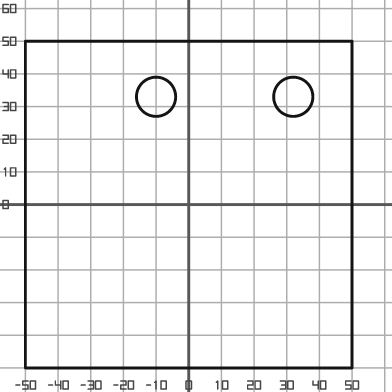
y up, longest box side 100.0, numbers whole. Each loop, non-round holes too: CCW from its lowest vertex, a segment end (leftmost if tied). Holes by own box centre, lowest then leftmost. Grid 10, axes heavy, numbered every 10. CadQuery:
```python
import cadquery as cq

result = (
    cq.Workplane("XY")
    .moveTo(-50.0, -50.0)
    .lineTo(50.0, -50.0)
    .lineTo(50.0, 50.0)
    .lineTo(-50.0, 50.0)
    .close()
    .moveTo(-10.0, 33.0)
    .circle(6.0)
    .moveTo(32.0, 33.0)
    .circle(6.0)
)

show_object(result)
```